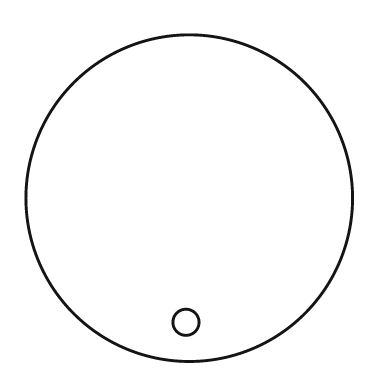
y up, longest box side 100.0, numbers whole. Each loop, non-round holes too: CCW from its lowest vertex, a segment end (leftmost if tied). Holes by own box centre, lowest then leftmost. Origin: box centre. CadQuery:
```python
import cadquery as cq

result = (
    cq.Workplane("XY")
    .moveTo(0.0, 0.0)
    .circle(50.0)
    .moveTo(-1.0, -38.0)
    .circle(4.0)
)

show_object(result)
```